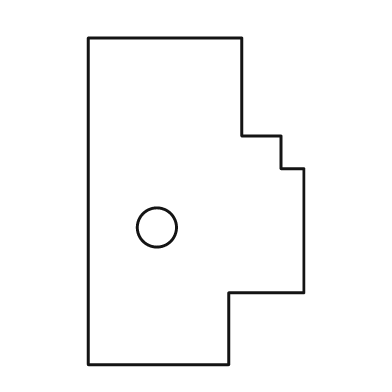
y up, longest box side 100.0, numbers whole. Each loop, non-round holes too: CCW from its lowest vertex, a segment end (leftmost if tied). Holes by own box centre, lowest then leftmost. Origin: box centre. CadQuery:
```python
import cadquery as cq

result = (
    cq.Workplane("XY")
    .moveTo(-33.0, -50.0)
    .lineTo(10.0, -50.0)
    .lineTo(10.0, -28.0)
    .lineTo(33.0, -28.0)
    .lineTo(33.0, 10.0)
    .lineTo(26.0, 10.0)
    .lineTo(26.0, 20.0)
    .lineTo(14.0, 20.0)
    .lineTo(14.0, 50.0)
    .lineTo(-33.0, 50.0)
    .close()
    .moveTo(-12.0, -8.0)
    .circle(6.0)
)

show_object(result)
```